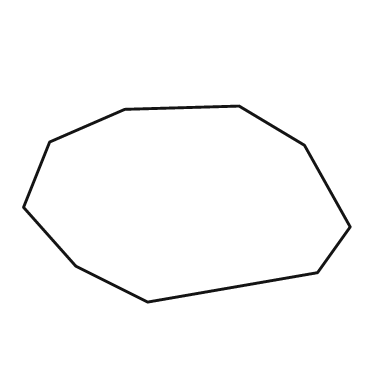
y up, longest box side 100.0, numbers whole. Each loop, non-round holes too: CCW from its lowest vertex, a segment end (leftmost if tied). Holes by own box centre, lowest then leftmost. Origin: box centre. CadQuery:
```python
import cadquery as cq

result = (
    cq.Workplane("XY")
    .moveTo(-12.0, -30.0)
    .lineTo(40.0, -21.0)
    .lineTo(50.0, -7.0)
    .lineTo(36.0, 18.0)
    .lineTo(16.0, 30.0)
    .lineTo(-19.0, 29.0)
    .lineTo(-42.0, 19.0)
    .lineTo(-50.0, -1.0)
    .lineTo(-34.0, -19.0)
    .close()
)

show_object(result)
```